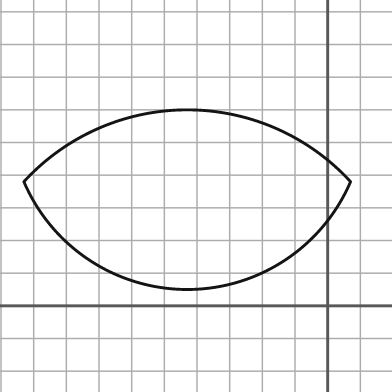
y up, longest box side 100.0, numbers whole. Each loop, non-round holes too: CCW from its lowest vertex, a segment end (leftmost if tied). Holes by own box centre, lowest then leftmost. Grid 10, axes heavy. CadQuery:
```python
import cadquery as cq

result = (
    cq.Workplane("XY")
    .moveTo(-93.0, 38.0)
    .threePointArc((-43.0, 5.0), (7.0, 38.0))
    .threePointArc((-43.0, 60.0), (-93.0, 38.0))
    .close()
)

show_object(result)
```